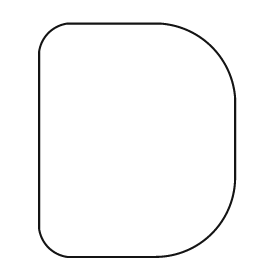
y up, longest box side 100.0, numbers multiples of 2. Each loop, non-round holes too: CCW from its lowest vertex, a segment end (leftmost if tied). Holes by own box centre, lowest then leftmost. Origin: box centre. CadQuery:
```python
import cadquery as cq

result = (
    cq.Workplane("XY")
    .moveTo(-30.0, -50.0)
    .lineTo(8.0, -50.0)
    .threePointArc((32.0, -40.0), (42.0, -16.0))
    .lineTo(42.0, 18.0)
    .threePointArc((32.0, 40.0), (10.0, 50.0))
    .lineTo(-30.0, 50.0)
    .threePointArc((-38.0, 46.0), (-42.0, 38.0))
    .lineTo(-42.0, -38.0)
    .threePointArc((-38.0, -46.0), (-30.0, -50.0))
    .close()
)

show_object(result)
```